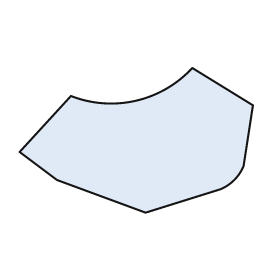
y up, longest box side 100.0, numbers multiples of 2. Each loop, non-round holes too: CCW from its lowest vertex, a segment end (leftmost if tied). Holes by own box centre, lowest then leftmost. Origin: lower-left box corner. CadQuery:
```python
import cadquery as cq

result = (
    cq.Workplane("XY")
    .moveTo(54.0, 0.0)
    .lineTo(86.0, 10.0)
    .threePointArc((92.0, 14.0), (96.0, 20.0))
    .lineTo(100.0, 46.0)
    .lineTo(74.0, 62.0)
    .threePointArc((50.0, 48.0), (22.0, 50.0))
    .lineTo(0.0, 26.0)
    .lineTo(16.0, 14.0)
    .close()
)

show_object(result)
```